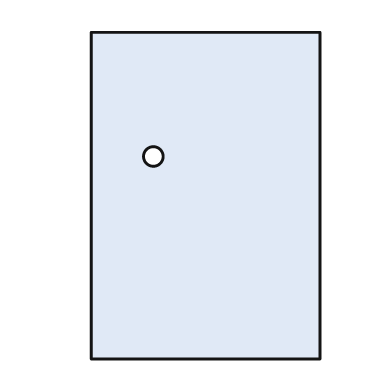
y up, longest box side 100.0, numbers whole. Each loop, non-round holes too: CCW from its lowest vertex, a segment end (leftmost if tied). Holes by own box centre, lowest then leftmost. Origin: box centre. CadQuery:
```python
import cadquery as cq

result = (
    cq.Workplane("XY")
    .moveTo(-35.0, -50.0)
    .lineTo(35.0, -50.0)
    .lineTo(35.0, 50.0)
    .lineTo(-35.0, 50.0)
    .close()
    .moveTo(-16.0, 12.0)
    .circle(3.0)
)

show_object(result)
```